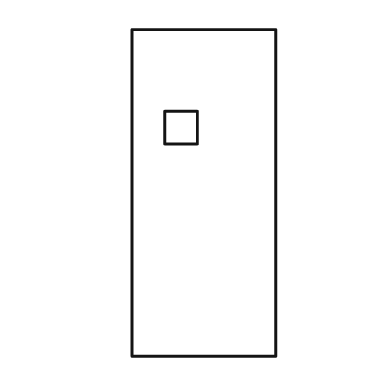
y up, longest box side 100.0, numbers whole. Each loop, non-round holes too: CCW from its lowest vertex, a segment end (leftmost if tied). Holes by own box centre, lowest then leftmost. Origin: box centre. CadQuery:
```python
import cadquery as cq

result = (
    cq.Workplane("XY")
    .moveTo(-22.0, -50.0)
    .lineTo(22.0, -50.0)
    .lineTo(22.0, 50.0)
    .lineTo(-22.0, 50.0)
    .close()
    .moveTo(-12.0, 15.0)
    .lineTo(-2.0, 15.0)
    .lineTo(-2.0, 25.0)
    .lineTo(-12.0, 25.0)
    .close()
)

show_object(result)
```